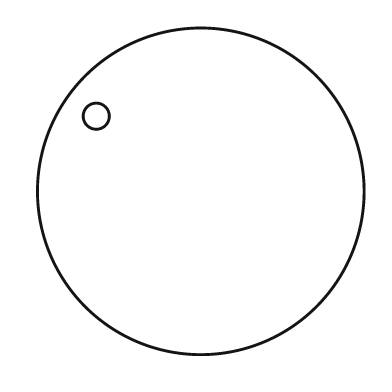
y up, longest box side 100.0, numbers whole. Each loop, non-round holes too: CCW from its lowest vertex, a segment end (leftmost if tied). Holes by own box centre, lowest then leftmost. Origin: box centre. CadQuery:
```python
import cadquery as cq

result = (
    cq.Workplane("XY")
    .moveTo(0.0, 0.0)
    .circle(50.0)
    .moveTo(-32.0, 23.0)
    .circle(4.0)
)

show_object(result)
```